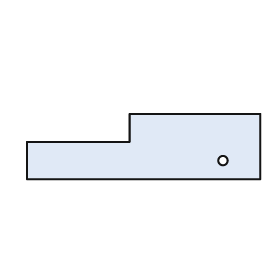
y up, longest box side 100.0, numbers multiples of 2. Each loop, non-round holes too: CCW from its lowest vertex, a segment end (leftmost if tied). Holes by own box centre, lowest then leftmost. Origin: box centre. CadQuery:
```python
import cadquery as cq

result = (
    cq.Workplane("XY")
    .moveTo(-50.0, -14.0)
    .lineTo(50.0, -14.0)
    .lineTo(50.0, 14.0)
    .lineTo(-6.0, 14.0)
    .lineTo(-6.0, 2.0)
    .lineTo(-50.0, 2.0)
    .close()
    .moveTo(34.0, -6.0)
    .circle(2.0)
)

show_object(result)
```